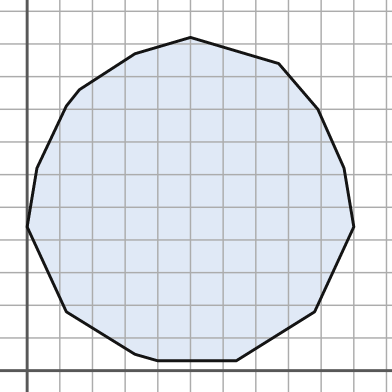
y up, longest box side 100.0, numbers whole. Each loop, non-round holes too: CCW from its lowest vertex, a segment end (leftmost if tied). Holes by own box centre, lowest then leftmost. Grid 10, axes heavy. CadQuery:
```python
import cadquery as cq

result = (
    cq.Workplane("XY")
    .moveTo(40.0, 3.0)
    .lineTo(64.0, 3.0)
    .lineTo(88.0, 18.0)
    .lineTo(100.0, 44.0)
    .lineTo(97.0, 62.0)
    .lineTo(89.0, 80.0)
    .lineTo(77.0, 94.0)
    .lineTo(50.0, 102.0)
    .lineTo(33.0, 97.0)
    .lineTo(16.0, 86.0)
    .lineTo(12.0, 81.0)
    .lineTo(3.0, 62.0)
    .lineTo(0.0, 44.0)
    .lineTo(12.0, 18.0)
    .lineTo(33.0, 5.0)
    .close()
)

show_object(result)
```